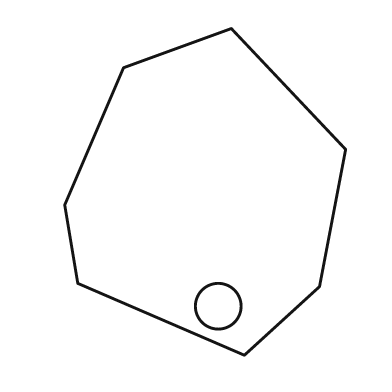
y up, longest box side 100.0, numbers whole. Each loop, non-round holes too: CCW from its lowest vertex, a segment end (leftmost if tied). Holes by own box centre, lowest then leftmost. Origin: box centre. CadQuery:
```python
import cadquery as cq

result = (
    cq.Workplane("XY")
    .moveTo(12.0, -50.0)
    .lineTo(35.0, -29.0)
    .lineTo(43.0, 13.0)
    .lineTo(8.0, 50.0)
    .lineTo(-25.0, 38.0)
    .lineTo(-43.0, -4.0)
    .lineTo(-39.0, -28.0)
    .close()
    .moveTo(4.0, -35.0)
    .circle(7.0)
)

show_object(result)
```